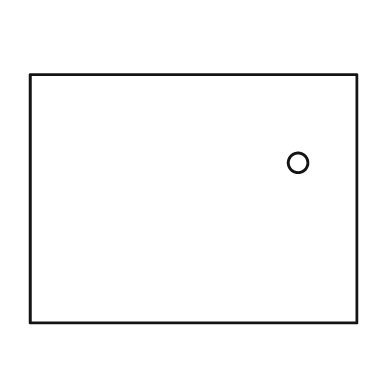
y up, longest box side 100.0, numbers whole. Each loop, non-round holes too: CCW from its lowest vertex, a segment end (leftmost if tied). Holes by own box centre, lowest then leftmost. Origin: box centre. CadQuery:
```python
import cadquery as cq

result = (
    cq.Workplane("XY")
    .moveTo(-50.0, -38.0)
    .lineTo(50.0, -38.0)
    .lineTo(50.0, 38.0)
    .lineTo(-50.0, 38.0)
    .close()
    .moveTo(32.0, 11.0)
    .circle(3.0)
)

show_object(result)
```